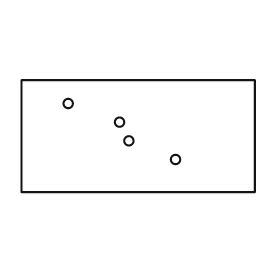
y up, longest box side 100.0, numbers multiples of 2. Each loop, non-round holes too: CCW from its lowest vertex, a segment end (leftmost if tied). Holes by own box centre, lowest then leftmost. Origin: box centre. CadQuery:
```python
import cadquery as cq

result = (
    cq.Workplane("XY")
    .moveTo(-50.0, -24.0)
    .lineTo(50.0, -24.0)
    .lineTo(50.0, 24.0)
    .lineTo(-50.0, 24.0)
    .close()
    .moveTo(16.0, -10.0)
    .circle(2.0)
    .moveTo(-4.0, -2.0)
    .circle(2.0)
    .moveTo(-8.0, 6.0)
    .circle(2.0)
    .moveTo(-30.0, 14.0)
    .circle(2.0)
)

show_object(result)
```